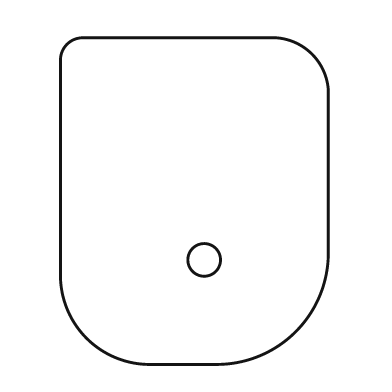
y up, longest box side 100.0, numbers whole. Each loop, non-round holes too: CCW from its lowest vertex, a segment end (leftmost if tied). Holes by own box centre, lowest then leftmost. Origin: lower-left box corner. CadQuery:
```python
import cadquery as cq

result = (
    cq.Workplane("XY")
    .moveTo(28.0, 0.0)
    .lineTo(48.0, 0.0)
    .threePointArc((72.0, 10.0), (82.0, 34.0))
    .lineTo(82.0, 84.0)
    .threePointArc((77.0, 95.0), (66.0, 100.0))
    .lineTo(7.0, 100.0)
    .threePointArc((2.0, 98.0), (0.0, 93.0))
    .lineTo(0.0, 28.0)
    .threePointArc((8.0, 8.0), (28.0, 0.0))
    .close()
    .moveTo(44.0, 32.0)
    .circle(5.0)
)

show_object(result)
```